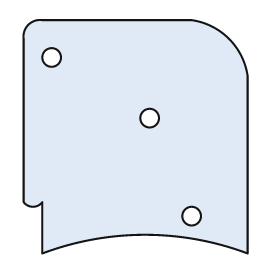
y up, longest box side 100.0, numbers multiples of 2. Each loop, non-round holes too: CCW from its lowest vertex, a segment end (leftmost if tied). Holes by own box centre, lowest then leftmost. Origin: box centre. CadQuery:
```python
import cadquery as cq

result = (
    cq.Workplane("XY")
    .moveTo(-40.0, -50.0)
    .threePointArc((4.0, -42.0), (48.0, -50.0))
    .lineTo(48.0, 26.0)
    .threePointArc((40.0, 42.0), (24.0, 50.0))
    .lineTo(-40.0, 50.0)
    .threePointArc((-46.0, 48.0), (-48.0, 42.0))
    .lineTo(-48.0, -28.0)
    .threePointArc((-44.0, -30.0), (-40.0, -28.0))
    .close()
    .moveTo(24.0, -34.0)
    .circle(4.0)
    .moveTo(6.0, 8.0)
    .circle(4.0)
    .moveTo(-36.0, 34.0)
    .circle(4.0)
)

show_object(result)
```